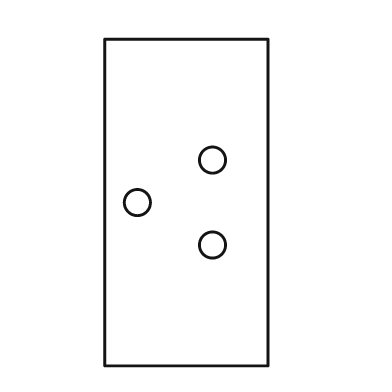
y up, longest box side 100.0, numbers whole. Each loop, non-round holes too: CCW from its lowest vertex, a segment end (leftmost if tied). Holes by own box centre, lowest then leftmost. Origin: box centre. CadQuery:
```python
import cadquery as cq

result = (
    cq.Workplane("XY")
    .moveTo(-25.0, -50.0)
    .lineTo(25.0, -50.0)
    .lineTo(25.0, 50.0)
    .lineTo(-25.0, 50.0)
    .close()
    .moveTo(8.0, -13.0)
    .circle(4.0)
    .moveTo(-15.0, 0.0)
    .circle(4.0)
    .moveTo(8.0, 13.0)
    .circle(4.0)
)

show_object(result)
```